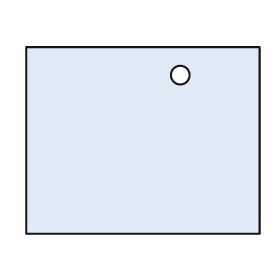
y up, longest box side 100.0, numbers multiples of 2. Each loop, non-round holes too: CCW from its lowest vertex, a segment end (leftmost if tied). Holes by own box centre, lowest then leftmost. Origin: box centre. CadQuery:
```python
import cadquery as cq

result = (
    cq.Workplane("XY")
    .moveTo(-50.0, -40.0)
    .lineTo(50.0, -40.0)
    .lineTo(50.0, 40.0)
    .lineTo(-50.0, 40.0)
    .close()
    .moveTo(16.0, 28.0)
    .circle(4.0)
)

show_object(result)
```